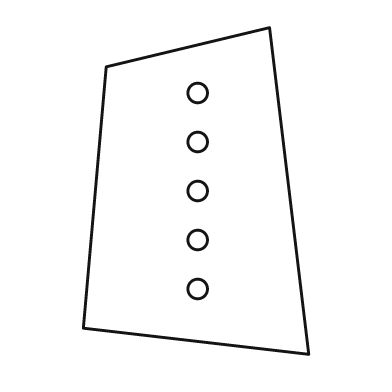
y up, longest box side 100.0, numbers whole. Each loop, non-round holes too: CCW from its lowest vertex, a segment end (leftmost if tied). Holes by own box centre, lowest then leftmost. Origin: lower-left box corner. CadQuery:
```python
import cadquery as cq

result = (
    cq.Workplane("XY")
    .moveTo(69.0, 0.0)
    .lineTo(57.0, 100.0)
    .lineTo(7.0, 88.0)
    .lineTo(0.0, 8.0)
    .close()
    .moveTo(35.0, 20.0)
    .circle(3.0)
    .moveTo(35.0, 35.0)
    .circle(3.0)
    .moveTo(35.0, 50.0)
    .circle(3.0)
    .moveTo(35.0, 65.0)
    .circle(3.0)
    .moveTo(35.0, 80.0)
    .circle(3.0)
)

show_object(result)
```